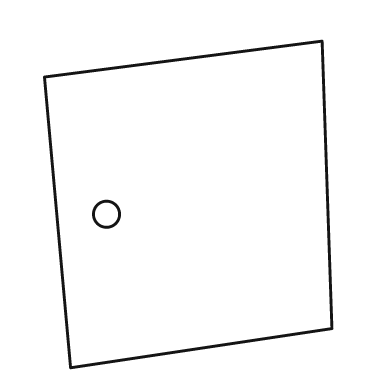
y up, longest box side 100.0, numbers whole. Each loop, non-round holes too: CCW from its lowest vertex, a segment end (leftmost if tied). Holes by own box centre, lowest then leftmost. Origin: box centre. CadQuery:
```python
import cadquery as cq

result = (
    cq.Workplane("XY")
    .moveTo(-36.0, -50.0)
    .lineTo(44.0, -38.0)
    .lineTo(41.0, 50.0)
    .lineTo(-44.0, 39.0)
    .close()
    .moveTo(-25.0, -3.0)
    .circle(4.0)
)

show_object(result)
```